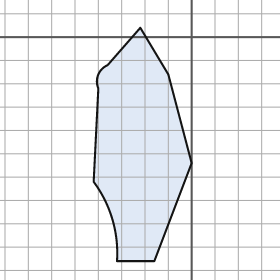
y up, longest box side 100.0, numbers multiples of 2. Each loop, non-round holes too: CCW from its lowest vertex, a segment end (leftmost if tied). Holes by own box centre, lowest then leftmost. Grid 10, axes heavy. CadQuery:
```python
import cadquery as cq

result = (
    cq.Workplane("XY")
    .moveTo(-32.0, -96.0)
    .lineTo(-16.0, -96.0)
    .lineTo(0.0, -54.0)
    .lineTo(-10.0, -16.0)
    .lineTo(-22.0, 4.0)
    .lineTo(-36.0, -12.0)
    .threePointArc((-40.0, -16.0), (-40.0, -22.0))
    .lineTo(-42.0, -62.0)
    .threePointArc((-34.0, -78.0), (-32.0, -96.0))
    .close()
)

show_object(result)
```